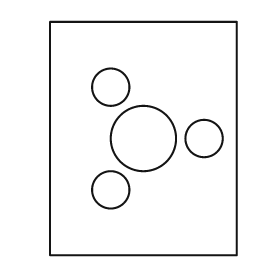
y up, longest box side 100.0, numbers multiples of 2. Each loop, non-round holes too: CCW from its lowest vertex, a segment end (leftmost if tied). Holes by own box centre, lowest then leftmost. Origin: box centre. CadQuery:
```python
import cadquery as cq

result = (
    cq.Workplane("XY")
    .moveTo(-40.0, -50.0)
    .lineTo(40.0, -50.0)
    .lineTo(40.0, 50.0)
    .lineTo(-40.0, 50.0)
    .close()
    .moveTo(-14.0, -22.0)
    .circle(8.0)
    .moveTo(0.0, 0.0)
    .circle(14.0)
    .moveTo(26.0, 0.0)
    .circle(8.0)
    .moveTo(-14.0, 22.0)
    .circle(8.0)
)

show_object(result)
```